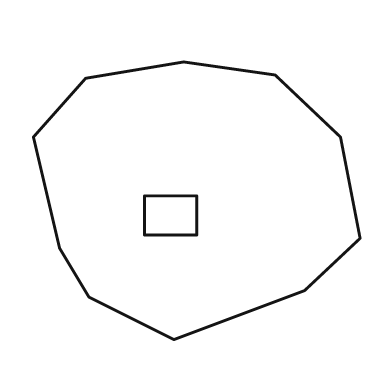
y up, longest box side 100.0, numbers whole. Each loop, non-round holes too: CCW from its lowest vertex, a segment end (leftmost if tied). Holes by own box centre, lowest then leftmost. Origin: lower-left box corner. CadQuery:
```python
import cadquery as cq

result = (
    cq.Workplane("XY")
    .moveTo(43.0, 0.0)
    .lineTo(83.0, 15.0)
    .lineTo(100.0, 31.0)
    .lineTo(94.0, 62.0)
    .lineTo(74.0, 81.0)
    .lineTo(46.0, 85.0)
    .lineTo(16.0, 80.0)
    .lineTo(0.0, 62.0)
    .lineTo(8.0, 28.0)
    .lineTo(17.0, 13.0)
    .close()
    .moveTo(34.0, 32.0)
    .lineTo(50.0, 32.0)
    .lineTo(50.0, 44.0)
    .lineTo(34.0, 44.0)
    .close()
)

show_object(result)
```